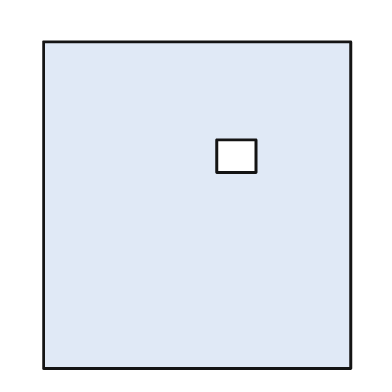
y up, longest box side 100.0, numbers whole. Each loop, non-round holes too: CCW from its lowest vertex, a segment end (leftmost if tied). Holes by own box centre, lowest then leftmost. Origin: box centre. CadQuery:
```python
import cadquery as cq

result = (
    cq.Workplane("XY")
    .moveTo(-47.0, -50.0)
    .lineTo(47.0, -50.0)
    .lineTo(47.0, 50.0)
    .lineTo(-47.0, 50.0)
    .close()
    .moveTo(6.0, 10.0)
    .lineTo(18.0, 10.0)
    .lineTo(18.0, 20.0)
    .lineTo(6.0, 20.0)
    .close()
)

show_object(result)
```